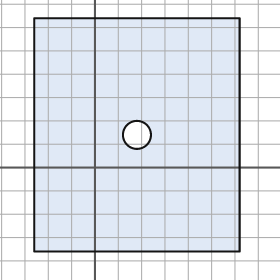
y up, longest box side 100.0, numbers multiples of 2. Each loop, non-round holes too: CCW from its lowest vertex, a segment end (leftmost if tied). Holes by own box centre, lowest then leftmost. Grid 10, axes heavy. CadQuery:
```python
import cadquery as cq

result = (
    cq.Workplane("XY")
    .moveTo(-26.0, -36.0)
    .lineTo(62.0, -36.0)
    .lineTo(62.0, 64.0)
    .lineTo(-26.0, 64.0)
    .close()
    .moveTo(18.0, 14.0)
    .circle(6.0)
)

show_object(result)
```